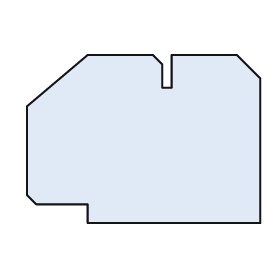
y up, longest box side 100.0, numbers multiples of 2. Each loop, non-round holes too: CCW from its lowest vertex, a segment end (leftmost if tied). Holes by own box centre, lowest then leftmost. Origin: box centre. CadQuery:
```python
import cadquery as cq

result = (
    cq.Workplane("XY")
    .moveTo(-24.0, -36.0)
    .lineTo(50.0, -36.0)
    .lineTo(50.0, 26.0)
    .lineTo(40.0, 36.0)
    .lineTo(12.0, 36.0)
    .lineTo(12.0, 22.0)
    .lineTo(8.0, 22.0)
    .lineTo(8.0, 32.0)
    .lineTo(4.0, 36.0)
    .lineTo(-24.0, 36.0)
    .lineTo(-50.0, 14.0)
    .lineTo(-50.0, -24.0)
    .lineTo(-46.0, -28.0)
    .lineTo(-24.0, -28.0)
    .close()
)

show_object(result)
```